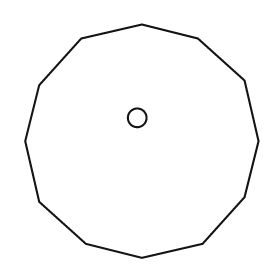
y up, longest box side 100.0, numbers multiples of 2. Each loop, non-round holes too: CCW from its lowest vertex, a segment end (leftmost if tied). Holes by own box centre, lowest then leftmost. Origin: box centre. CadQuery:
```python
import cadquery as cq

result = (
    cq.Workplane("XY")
    .moveTo(0.0, -50.0)
    .lineTo(26.0, -44.0)
    .lineTo(44.0, -24.0)
    .lineTo(50.0, 0.0)
    .lineTo(44.0, 26.0)
    .lineTo(24.0, 44.0)
    .lineTo(0.0, 50.0)
    .lineTo(-26.0, 44.0)
    .lineTo(-44.0, 24.0)
    .lineTo(-50.0, 0.0)
    .lineTo(-44.0, -26.0)
    .lineTo(-24.0, -44.0)
    .close()
    .moveTo(-2.0, 10.0)
    .circle(4.0)
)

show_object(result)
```